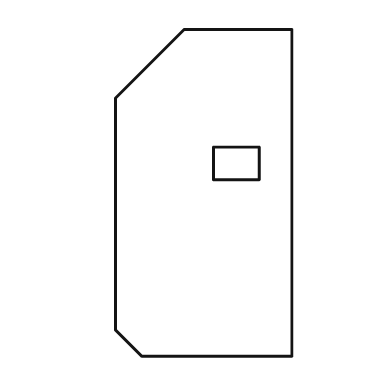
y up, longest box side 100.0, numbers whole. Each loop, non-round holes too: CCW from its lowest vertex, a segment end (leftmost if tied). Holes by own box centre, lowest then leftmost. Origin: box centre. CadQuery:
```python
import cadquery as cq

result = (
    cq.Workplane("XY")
    .moveTo(-19.0, -50.0)
    .lineTo(27.0, -50.0)
    .lineTo(27.0, 50.0)
    .lineTo(-6.0, 50.0)
    .lineTo(-27.0, 29.0)
    .lineTo(-27.0, -42.0)
    .close()
    .moveTo(3.0, 4.0)
    .lineTo(17.0, 4.0)
    .lineTo(17.0, 14.0)
    .lineTo(3.0, 14.0)
    .close()
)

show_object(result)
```